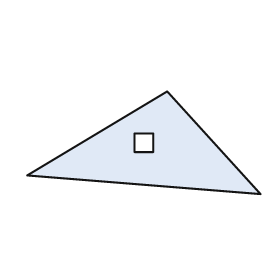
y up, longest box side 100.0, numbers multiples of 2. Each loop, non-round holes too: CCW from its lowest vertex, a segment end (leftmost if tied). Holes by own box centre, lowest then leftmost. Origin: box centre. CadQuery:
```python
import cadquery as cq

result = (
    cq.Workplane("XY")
    .moveTo(50.0, -22.0)
    .lineTo(10.0, 22.0)
    .lineTo(-50.0, -14.0)
    .close()
    .moveTo(-4.0, -4.0)
    .lineTo(4.0, -4.0)
    .lineTo(4.0, 4.0)
    .lineTo(-4.0, 4.0)
    .close()
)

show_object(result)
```